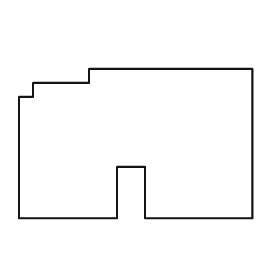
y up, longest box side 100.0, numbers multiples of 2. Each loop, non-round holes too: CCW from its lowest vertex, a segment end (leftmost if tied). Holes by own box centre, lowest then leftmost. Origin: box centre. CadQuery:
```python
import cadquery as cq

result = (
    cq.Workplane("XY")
    .moveTo(-50.0, -32.0)
    .lineTo(-8.0, -32.0)
    .lineTo(-8.0, -10.0)
    .lineTo(4.0, -10.0)
    .lineTo(4.0, -32.0)
    .lineTo(50.0, -32.0)
    .lineTo(50.0, 32.0)
    .lineTo(-20.0, 32.0)
    .lineTo(-20.0, 26.0)
    .lineTo(-44.0, 26.0)
    .lineTo(-44.0, 20.0)
    .lineTo(-50.0, 20.0)
    .close()
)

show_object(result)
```